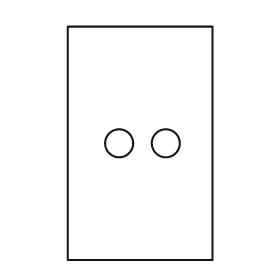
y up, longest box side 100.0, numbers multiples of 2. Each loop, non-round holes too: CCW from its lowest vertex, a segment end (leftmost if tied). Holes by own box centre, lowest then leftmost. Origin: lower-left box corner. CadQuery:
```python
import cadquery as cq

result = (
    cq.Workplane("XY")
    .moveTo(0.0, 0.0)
    .lineTo(62.0, 0.0)
    .lineTo(62.0, 100.0)
    .lineTo(0.0, 100.0)
    .close()
    .moveTo(22.0, 50.0)
    .circle(6.0)
    .moveTo(42.0, 50.0)
    .circle(6.0)
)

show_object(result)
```